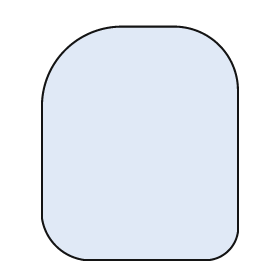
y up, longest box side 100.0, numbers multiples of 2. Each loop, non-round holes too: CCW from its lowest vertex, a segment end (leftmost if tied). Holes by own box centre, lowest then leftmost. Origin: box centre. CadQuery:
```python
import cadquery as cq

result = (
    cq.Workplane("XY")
    .moveTo(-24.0, -50.0)
    .lineTo(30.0, -50.0)
    .threePointArc((38.0, -46.0), (42.0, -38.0))
    .lineTo(42.0, 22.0)
    .threePointArc((34.0, 42.0), (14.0, 50.0))
    .lineTo(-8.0, 50.0)
    .threePointArc((-32.0, 40.0), (-42.0, 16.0))
    .lineTo(-42.0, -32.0)
    .threePointArc((-36.0, -44.0), (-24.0, -50.0))
    .close()
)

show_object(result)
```